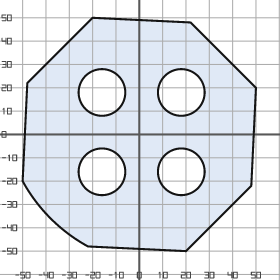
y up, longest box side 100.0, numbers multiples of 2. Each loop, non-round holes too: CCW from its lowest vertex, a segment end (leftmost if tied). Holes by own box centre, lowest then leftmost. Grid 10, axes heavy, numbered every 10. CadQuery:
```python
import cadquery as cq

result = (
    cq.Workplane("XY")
    .moveTo(20.0, -50.0)
    .lineTo(48.0, -22.0)
    .lineTo(50.0, 20.0)
    .lineTo(22.0, 48.0)
    .lineTo(-20.0, 50.0)
    .lineTo(-48.0, 22.0)
    .lineTo(-50.0, -20.0)
    .threePointArc((-38.0, -36.0), (-22.0, -48.0))
    .close()
    .moveTo(-16.0, -16.0)
    .circle(10.0)
    .moveTo(18.0, -16.0)
    .circle(10.0)
    .moveTo(-16.0, 18.0)
    .circle(10.0)
    .moveTo(18.0, 18.0)
    .circle(10.0)
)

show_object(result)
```